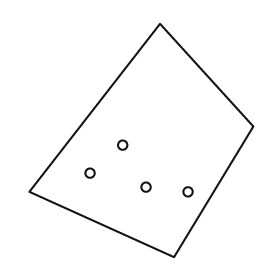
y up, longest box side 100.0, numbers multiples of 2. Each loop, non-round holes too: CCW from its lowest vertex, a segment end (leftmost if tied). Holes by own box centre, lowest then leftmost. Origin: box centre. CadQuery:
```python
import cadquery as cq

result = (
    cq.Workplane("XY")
    .moveTo(14.0, -50.0)
    .lineTo(48.0, 6.0)
    .lineTo(8.0, 50.0)
    .lineTo(-48.0, -22.0)
    .close()
    .moveTo(20.0, -22.0)
    .circle(2.0)
    .moveTo(2.0, -20.0)
    .circle(2.0)
    .moveTo(-22.0, -14.0)
    .circle(2.0)
    .moveTo(-8.0, -2.0)
    .circle(2.0)
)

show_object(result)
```